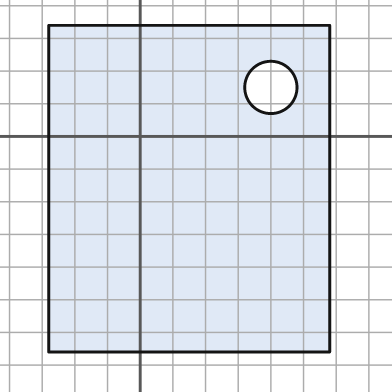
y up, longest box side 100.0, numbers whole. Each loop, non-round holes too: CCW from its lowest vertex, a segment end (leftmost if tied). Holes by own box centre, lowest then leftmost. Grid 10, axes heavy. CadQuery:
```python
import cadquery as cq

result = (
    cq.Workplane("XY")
    .moveTo(-28.0, -66.0)
    .lineTo(58.0, -66.0)
    .lineTo(58.0, 34.0)
    .lineTo(-28.0, 34.0)
    .close()
    .moveTo(40.0, 15.0)
    .circle(8.0)
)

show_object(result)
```